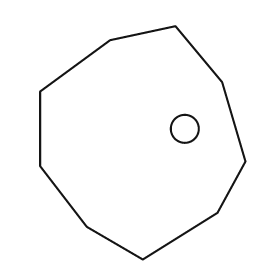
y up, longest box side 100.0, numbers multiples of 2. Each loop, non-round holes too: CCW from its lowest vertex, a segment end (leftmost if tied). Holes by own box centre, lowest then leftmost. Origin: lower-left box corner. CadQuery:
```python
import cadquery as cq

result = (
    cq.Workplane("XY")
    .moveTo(44.0, 0.0)
    .lineTo(76.0, 20.0)
    .lineTo(88.0, 42.0)
    .lineTo(78.0, 76.0)
    .lineTo(58.0, 100.0)
    .lineTo(30.0, 94.0)
    .lineTo(0.0, 72.0)
    .lineTo(0.0, 40.0)
    .lineTo(20.0, 14.0)
    .close()
    .moveTo(62.0, 56.0)
    .circle(6.0)
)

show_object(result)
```